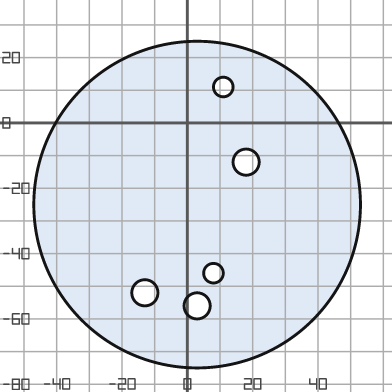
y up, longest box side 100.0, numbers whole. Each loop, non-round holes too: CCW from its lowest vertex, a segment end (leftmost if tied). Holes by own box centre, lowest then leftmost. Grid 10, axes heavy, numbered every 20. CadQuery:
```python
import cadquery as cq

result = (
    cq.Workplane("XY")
    .moveTo(3.0, -25.0)
    .circle(50.0)
    .moveTo(3.0, -56.0)
    .circle(4.0)
    .moveTo(-13.0, -52.0)
    .circle(4.0)
    .moveTo(8.0, -46.0)
    .circle(3.0)
    .moveTo(18.0, -12.0)
    .circle(4.0)
    .moveTo(11.0, 11.0)
    .circle(3.0)
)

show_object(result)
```